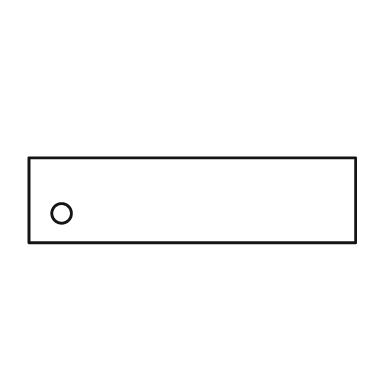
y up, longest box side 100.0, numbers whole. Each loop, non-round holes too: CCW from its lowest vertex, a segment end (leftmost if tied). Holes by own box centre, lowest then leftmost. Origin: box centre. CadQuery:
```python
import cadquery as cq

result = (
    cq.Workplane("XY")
    .moveTo(-50.0, -13.0)
    .lineTo(50.0, -13.0)
    .lineTo(50.0, 13.0)
    .lineTo(-50.0, 13.0)
    .close()
    .moveTo(-40.0, -4.0)
    .circle(3.0)
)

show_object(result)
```